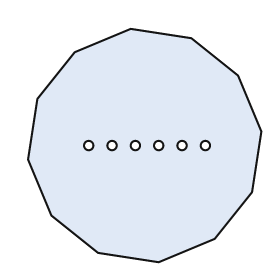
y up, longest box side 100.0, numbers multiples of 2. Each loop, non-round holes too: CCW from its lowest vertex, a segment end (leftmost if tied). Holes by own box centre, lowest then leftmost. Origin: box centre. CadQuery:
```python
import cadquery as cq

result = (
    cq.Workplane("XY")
    .moveTo(6.0, -50.0)
    .lineTo(30.0, -40.0)
    .lineTo(46.0, -20.0)
    .lineTo(50.0, 6.0)
    .lineTo(40.0, 30.0)
    .lineTo(20.0, 46.0)
    .lineTo(-6.0, 50.0)
    .lineTo(-30.0, 40.0)
    .lineTo(-46.0, 20.0)
    .lineTo(-50.0, -6.0)
    .lineTo(-40.0, -30.0)
    .lineTo(-20.0, -46.0)
    .close()
    .moveTo(-24.0, 0.0)
    .circle(2.0)
    .moveTo(-14.0, 0.0)
    .circle(2.0)
    .moveTo(-4.0, 0.0)
    .circle(2.0)
    .moveTo(6.0, 0.0)
    .circle(2.0)
    .moveTo(16.0, 0.0)
    .circle(2.0)
    .moveTo(26.0, 0.0)
    .circle(2.0)
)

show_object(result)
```